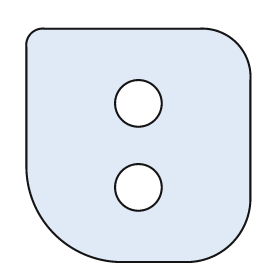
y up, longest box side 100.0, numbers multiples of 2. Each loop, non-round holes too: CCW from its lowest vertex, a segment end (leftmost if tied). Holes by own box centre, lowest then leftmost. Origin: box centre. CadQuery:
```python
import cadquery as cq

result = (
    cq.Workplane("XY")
    .moveTo(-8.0, -50.0)
    .lineTo(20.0, -50.0)
    .threePointArc((40.0, -42.0), (48.0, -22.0))
    .lineTo(48.0, 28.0)
    .threePointArc((42.0, 44.0), (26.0, 50.0))
    .lineTo(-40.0, 50.0)
    .threePointArc((-46.0, 48.0), (-48.0, 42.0))
    .lineTo(-48.0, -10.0)
    .threePointArc((-36.0, -38.0), (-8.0, -50.0))
    .close()
    .moveTo(0.0, -18.0)
    .circle(10.0)
    .moveTo(0.0, 18.0)
    .circle(10.0)
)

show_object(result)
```